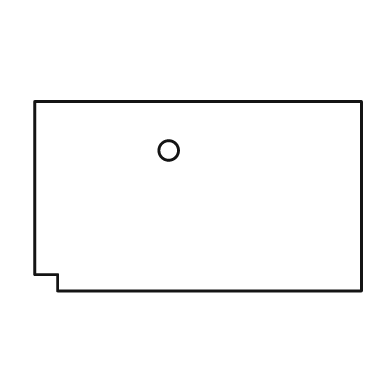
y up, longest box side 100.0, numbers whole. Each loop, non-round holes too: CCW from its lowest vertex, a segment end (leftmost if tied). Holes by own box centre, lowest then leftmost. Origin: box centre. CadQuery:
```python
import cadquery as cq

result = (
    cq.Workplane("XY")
    .moveTo(-43.0, -29.0)
    .lineTo(50.0, -29.0)
    .lineTo(50.0, 29.0)
    .lineTo(-50.0, 29.0)
    .lineTo(-50.0, -24.0)
    .lineTo(-43.0, -24.0)
    .close()
    .moveTo(-9.0, 14.0)
    .circle(3.0)
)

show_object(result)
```